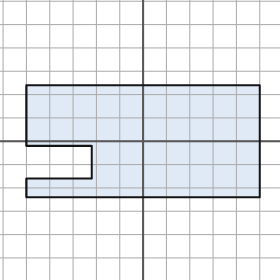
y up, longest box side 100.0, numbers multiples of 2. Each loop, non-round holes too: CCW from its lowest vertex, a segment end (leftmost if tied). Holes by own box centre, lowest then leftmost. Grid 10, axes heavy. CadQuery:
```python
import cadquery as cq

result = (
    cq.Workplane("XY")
    .moveTo(-50.0, -24.0)
    .lineTo(50.0, -24.0)
    .lineTo(50.0, 24.0)
    .lineTo(-50.0, 24.0)
    .lineTo(-50.0, -2.0)
    .lineTo(-22.0, -2.0)
    .lineTo(-22.0, -16.0)
    .lineTo(-50.0, -16.0)
    .close()
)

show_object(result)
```